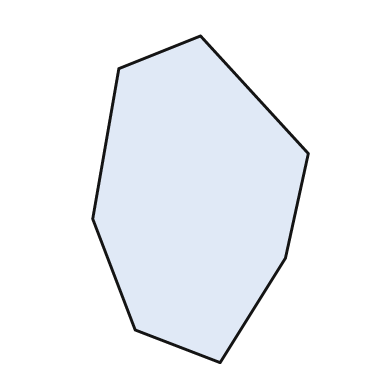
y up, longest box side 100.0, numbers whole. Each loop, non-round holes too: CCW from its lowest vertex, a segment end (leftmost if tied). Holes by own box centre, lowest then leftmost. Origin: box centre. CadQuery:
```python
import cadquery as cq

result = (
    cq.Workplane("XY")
    .moveTo(6.0, -50.0)
    .lineTo(26.0, -18.0)
    .lineTo(33.0, 14.0)
    .lineTo(0.0, 50.0)
    .lineTo(-25.0, 40.0)
    .lineTo(-33.0, -6.0)
    .lineTo(-20.0, -40.0)
    .close()
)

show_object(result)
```